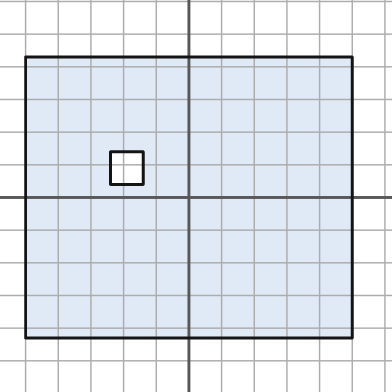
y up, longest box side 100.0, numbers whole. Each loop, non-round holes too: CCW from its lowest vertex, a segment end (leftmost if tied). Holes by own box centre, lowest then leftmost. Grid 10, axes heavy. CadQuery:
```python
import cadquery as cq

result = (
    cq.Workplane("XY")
    .moveTo(-50.0, -43.0)
    .lineTo(50.0, -43.0)
    .lineTo(50.0, 43.0)
    .lineTo(-50.0, 43.0)
    .close()
    .moveTo(-24.0, 4.0)
    .lineTo(-14.0, 4.0)
    .lineTo(-14.0, 14.0)
    .lineTo(-24.0, 14.0)
    .close()
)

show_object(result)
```